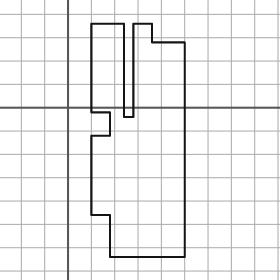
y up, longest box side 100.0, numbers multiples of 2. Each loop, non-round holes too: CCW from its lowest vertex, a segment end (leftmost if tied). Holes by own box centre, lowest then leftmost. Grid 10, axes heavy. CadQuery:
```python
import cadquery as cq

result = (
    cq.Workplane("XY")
    .moveTo(18.0, -64.0)
    .lineTo(50.0, -64.0)
    .lineTo(50.0, 28.0)
    .lineTo(36.0, 28.0)
    .lineTo(36.0, 36.0)
    .lineTo(28.0, 36.0)
    .lineTo(28.0, -4.0)
    .lineTo(24.0, -4.0)
    .lineTo(24.0, 36.0)
    .lineTo(10.0, 36.0)
    .lineTo(10.0, -2.0)
    .lineTo(18.0, -2.0)
    .lineTo(18.0, -12.0)
    .lineTo(10.0, -12.0)
    .lineTo(10.0, -46.0)
    .lineTo(18.0, -46.0)
    .close()
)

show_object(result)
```